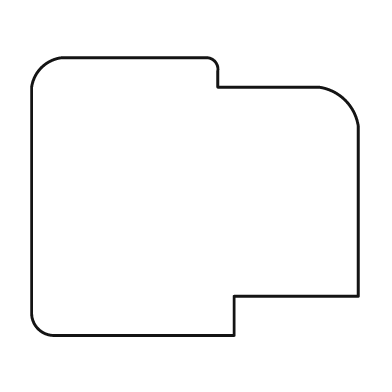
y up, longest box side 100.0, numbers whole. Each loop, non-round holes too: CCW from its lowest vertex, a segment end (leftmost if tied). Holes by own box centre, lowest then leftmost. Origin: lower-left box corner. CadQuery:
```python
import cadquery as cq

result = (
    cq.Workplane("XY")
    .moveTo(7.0, 0.0)
    .lineTo(62.0, 0.0)
    .lineTo(62.0, 12.0)
    .lineTo(100.0, 12.0)
    .lineTo(100.0, 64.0)
    .threePointArc((96.0, 72.0), (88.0, 76.0))
    .lineTo(57.0, 76.0)
    .lineTo(57.0, 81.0)
    .threePointArc((56.0, 84.0), (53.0, 85.0))
    .lineTo(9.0, 85.0)
    .threePointArc((3.0, 82.0), (0.0, 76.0))
    .lineTo(0.0, 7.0)
    .threePointArc((2.0, 2.0), (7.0, 0.0))
    .close()
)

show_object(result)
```